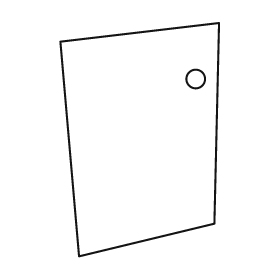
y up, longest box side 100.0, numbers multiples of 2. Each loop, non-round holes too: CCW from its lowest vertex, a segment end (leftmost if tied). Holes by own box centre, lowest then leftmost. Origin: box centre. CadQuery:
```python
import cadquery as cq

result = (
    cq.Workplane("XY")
    .moveTo(-26.0, -50.0)
    .lineTo(32.0, -36.0)
    .lineTo(34.0, 50.0)
    .lineTo(-34.0, 42.0)
    .close()
    .moveTo(24.0, 26.0)
    .circle(4.0)
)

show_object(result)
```